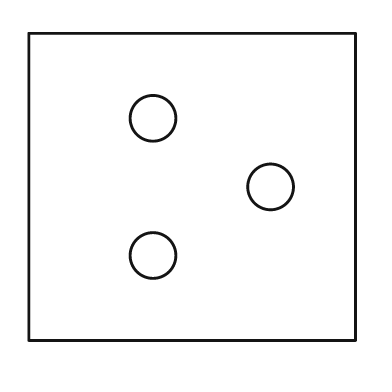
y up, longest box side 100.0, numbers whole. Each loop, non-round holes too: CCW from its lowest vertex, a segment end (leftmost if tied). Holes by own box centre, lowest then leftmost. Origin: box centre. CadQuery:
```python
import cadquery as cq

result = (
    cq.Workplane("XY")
    .moveTo(-50.0, -47.0)
    .lineTo(50.0, -47.0)
    .lineTo(50.0, 47.0)
    .lineTo(-50.0, 47.0)
    .close()
    .moveTo(-12.0, -21.0)
    .circle(7.0)
    .moveTo(24.0, 0.0)
    .circle(7.0)
    .moveTo(-12.0, 21.0)
    .circle(7.0)
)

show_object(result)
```